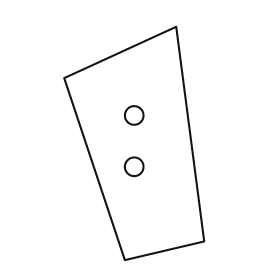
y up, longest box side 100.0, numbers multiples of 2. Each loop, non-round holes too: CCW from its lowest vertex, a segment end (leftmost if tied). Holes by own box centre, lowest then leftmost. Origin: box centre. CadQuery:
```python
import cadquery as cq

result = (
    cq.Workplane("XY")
    .moveTo(-4.0, -50.0)
    .lineTo(30.0, -42.0)
    .lineTo(18.0, 50.0)
    .lineTo(-30.0, 28.0)
    .close()
    .moveTo(0.0, -10.0)
    .circle(4.0)
    .moveTo(0.0, 12.0)
    .circle(4.0)
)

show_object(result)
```